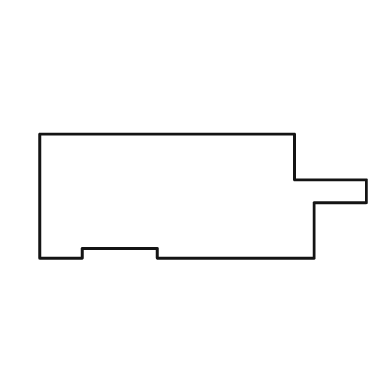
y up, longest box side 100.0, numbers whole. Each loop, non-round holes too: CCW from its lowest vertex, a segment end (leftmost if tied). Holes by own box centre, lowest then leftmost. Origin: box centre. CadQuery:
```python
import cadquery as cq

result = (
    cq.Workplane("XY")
    .moveTo(-50.0, -19.0)
    .lineTo(-37.0, -19.0)
    .lineTo(-37.0, -16.0)
    .lineTo(-14.0, -16.0)
    .lineTo(-14.0, -19.0)
    .lineTo(34.0, -19.0)
    .lineTo(34.0, -2.0)
    .lineTo(50.0, -2.0)
    .lineTo(50.0, 5.0)
    .lineTo(28.0, 5.0)
    .lineTo(28.0, 19.0)
    .lineTo(-50.0, 19.0)
    .close()
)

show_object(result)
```